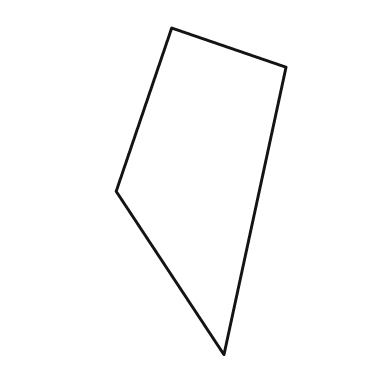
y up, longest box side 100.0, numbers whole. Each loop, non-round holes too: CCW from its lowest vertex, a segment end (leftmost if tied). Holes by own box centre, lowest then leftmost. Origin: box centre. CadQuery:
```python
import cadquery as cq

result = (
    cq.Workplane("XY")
    .moveTo(7.0, -50.0)
    .lineTo(26.0, 38.0)
    .lineTo(-9.0, 50.0)
    .lineTo(-26.0, 0.0)
    .close()
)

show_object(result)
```